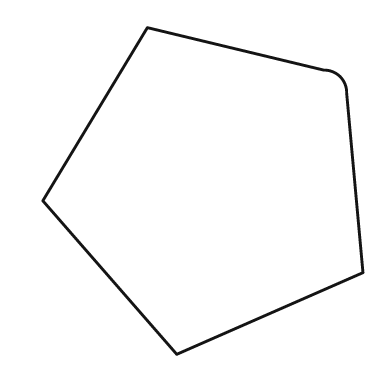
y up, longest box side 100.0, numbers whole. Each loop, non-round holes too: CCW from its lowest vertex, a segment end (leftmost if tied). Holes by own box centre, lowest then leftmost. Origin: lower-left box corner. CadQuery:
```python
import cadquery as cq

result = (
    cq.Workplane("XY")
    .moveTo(41.0, 0.0)
    .lineTo(98.0, 25.0)
    .lineTo(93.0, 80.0)
    .threePointArc((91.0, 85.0), (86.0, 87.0))
    .lineTo(32.0, 100.0)
    .lineTo(0.0, 47.0)
    .close()
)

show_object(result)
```